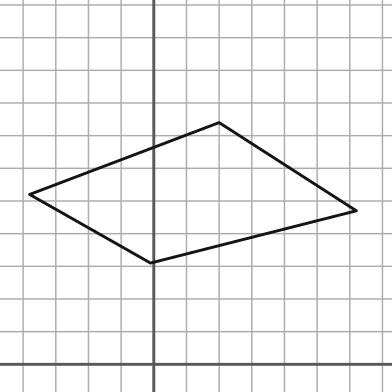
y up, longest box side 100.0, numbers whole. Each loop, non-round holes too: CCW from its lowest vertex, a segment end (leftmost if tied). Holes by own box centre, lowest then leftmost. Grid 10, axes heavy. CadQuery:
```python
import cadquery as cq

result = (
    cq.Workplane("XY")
    .moveTo(-1.0, 31.0)
    .lineTo(62.0, 47.0)
    .lineTo(20.0, 74.0)
    .lineTo(-38.0, 52.0)
    .close()
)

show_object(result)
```